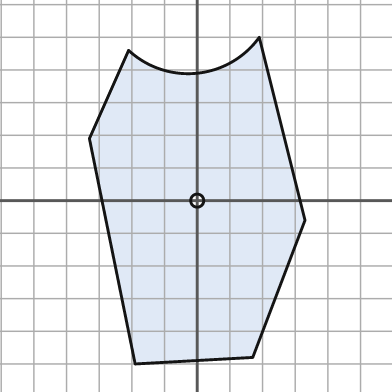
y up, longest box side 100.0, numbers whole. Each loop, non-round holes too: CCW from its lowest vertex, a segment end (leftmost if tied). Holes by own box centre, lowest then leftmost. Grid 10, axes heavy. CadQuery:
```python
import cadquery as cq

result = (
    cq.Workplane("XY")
    .moveTo(-19.0, -50.0)
    .lineTo(17.0, -48.0)
    .lineTo(33.0, -6.0)
    .lineTo(19.0, 50.0)
    .threePointArc((0.0, 39.0), (-21.0, 46.0))
    .lineTo(-33.0, 19.0)
    .close()
    .moveTo(0.0, 0.0)
    .circle(2.0)
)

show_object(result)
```